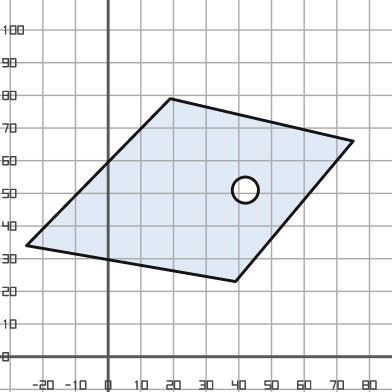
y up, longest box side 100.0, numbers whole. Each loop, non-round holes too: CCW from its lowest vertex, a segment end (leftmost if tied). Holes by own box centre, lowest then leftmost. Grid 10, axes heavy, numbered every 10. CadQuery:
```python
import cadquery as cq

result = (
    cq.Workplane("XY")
    .moveTo(39.0, 23.0)
    .lineTo(75.0, 66.0)
    .lineTo(19.0, 79.0)
    .lineTo(-25.0, 34.0)
    .close()
    .moveTo(42.0, 51.0)
    .circle(4.0)
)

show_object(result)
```